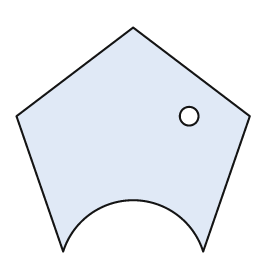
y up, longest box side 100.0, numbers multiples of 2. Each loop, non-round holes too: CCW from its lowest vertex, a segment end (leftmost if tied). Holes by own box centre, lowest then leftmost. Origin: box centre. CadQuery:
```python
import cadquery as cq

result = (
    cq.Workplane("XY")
    .moveTo(-30.0, -48.0)
    .threePointArc((0.0, -26.0), (30.0, -48.0))
    .lineTo(50.0, 10.0)
    .lineTo(0.0, 48.0)
    .lineTo(-50.0, 10.0)
    .close()
    .moveTo(24.0, 10.0)
    .circle(4.0)
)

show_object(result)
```